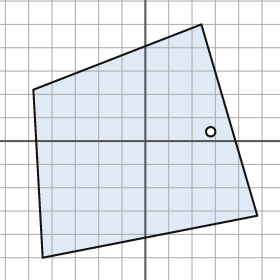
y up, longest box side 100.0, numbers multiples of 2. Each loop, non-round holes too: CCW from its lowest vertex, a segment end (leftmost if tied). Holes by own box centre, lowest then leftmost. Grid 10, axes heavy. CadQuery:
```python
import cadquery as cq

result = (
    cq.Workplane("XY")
    .moveTo(-44.0, -50.0)
    .lineTo(48.0, -32.0)
    .lineTo(24.0, 50.0)
    .lineTo(-48.0, 22.0)
    .close()
    .moveTo(28.0, 4.0)
    .circle(2.0)
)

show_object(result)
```